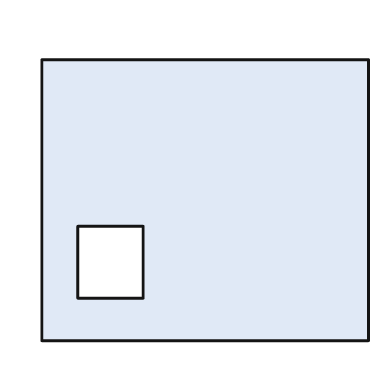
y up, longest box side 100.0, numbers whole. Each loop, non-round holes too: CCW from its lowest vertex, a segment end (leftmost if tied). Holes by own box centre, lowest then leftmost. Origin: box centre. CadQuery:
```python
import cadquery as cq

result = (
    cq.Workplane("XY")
    .moveTo(-50.0, -43.0)
    .lineTo(50.0, -43.0)
    .lineTo(50.0, 43.0)
    .lineTo(-50.0, 43.0)
    .close()
    .moveTo(-39.0, -30.0)
    .lineTo(-19.0, -30.0)
    .lineTo(-19.0, -8.0)
    .lineTo(-39.0, -8.0)
    .close()
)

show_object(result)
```